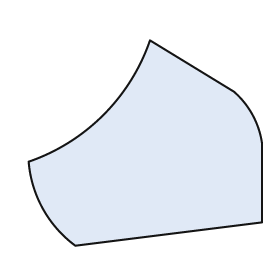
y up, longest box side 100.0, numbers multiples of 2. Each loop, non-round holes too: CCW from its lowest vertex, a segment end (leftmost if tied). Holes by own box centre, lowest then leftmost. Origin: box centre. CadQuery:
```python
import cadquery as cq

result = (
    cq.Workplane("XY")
    .moveTo(-30.0, -44.0)
    .lineTo(50.0, -34.0)
    .lineTo(50.0, 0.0)
    .threePointArc((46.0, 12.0), (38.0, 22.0))
    .lineTo(2.0, 44.0)
    .threePointArc((-18.0, 12.0), (-50.0, -8.0))
    .threePointArc((-44.0, -28.0), (-30.0, -44.0))
    .close()
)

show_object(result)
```